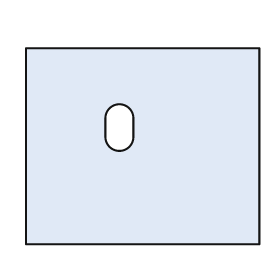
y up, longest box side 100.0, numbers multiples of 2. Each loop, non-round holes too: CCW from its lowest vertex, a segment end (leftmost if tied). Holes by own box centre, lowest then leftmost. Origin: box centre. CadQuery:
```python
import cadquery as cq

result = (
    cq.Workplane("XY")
    .moveTo(-50.0, -42.0)
    .lineTo(50.0, -42.0)
    .lineTo(50.0, 42.0)
    .lineTo(-50.0, 42.0)
    .close()
    .moveTo(-16.0, 4.0)
    .threePointArc((-10.0, -2.0), (-4.0, 4.0))
    .lineTo(-4.0, 12.0)
    .threePointArc((-10.0, 18.0), (-16.0, 12.0))
    .close()
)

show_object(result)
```